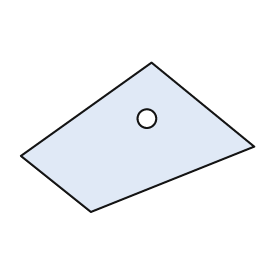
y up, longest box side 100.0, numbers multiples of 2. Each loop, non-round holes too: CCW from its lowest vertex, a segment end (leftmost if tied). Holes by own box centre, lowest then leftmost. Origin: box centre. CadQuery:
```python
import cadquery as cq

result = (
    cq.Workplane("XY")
    .moveTo(-20.0, -32.0)
    .lineTo(50.0, -4.0)
    .lineTo(6.0, 32.0)
    .lineTo(-50.0, -8.0)
    .close()
    .moveTo(4.0, 8.0)
    .circle(4.0)
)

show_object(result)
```